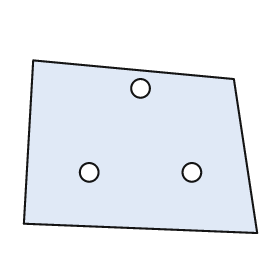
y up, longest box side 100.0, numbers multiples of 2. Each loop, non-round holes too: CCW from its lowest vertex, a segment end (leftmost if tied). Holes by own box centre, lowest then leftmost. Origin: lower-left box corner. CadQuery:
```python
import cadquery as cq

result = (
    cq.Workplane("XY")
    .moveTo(100.0, 0.0)
    .lineTo(90.0, 66.0)
    .lineTo(4.0, 74.0)
    .lineTo(0.0, 4.0)
    .close()
    .moveTo(28.0, 26.0)
    .circle(4.0)
    .moveTo(72.0, 26.0)
    .circle(4.0)
    .moveTo(50.0, 62.0)
    .circle(4.0)
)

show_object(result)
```